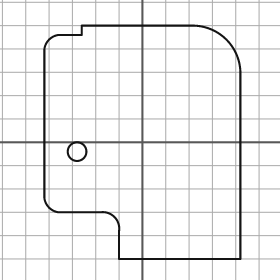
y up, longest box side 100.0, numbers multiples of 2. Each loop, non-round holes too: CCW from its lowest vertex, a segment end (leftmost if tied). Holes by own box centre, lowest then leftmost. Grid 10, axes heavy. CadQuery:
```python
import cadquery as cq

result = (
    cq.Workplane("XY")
    .moveTo(-10.0, -50.0)
    .lineTo(42.0, -50.0)
    .lineTo(42.0, 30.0)
    .threePointArc((36.0, 44.0), (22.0, 50.0))
    .lineTo(-26.0, 50.0)
    .lineTo(-26.0, 46.0)
    .lineTo(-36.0, 46.0)
    .threePointArc((-40.0, 44.0), (-42.0, 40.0))
    .lineTo(-42.0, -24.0)
    .threePointArc((-40.0, -28.0), (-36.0, -30.0))
    .lineTo(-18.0, -30.0)
    .threePointArc((-12.0, -32.0), (-10.0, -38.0))
    .close()
    .moveTo(-28.0, -4.0)
    .circle(4.0)
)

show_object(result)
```